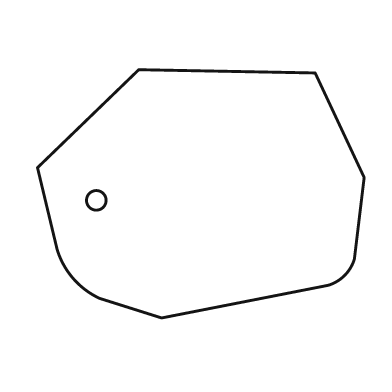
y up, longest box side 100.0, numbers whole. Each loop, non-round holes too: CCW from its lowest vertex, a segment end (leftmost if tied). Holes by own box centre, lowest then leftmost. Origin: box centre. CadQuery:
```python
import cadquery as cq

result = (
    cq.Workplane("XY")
    .moveTo(-12.0, -38.0)
    .lineTo(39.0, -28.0)
    .threePointArc((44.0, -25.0), (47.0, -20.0))
    .lineTo(50.0, 5.0)
    .lineTo(35.0, 37.0)
    .lineTo(-19.0, 38.0)
    .lineTo(-50.0, 8.0)
    .lineTo(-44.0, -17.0)
    .threePointArc((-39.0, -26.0), (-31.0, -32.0))
    .close()
    .moveTo(-32.0, -2.0)
    .circle(3.0)
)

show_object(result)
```